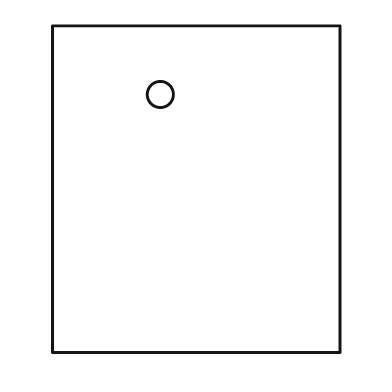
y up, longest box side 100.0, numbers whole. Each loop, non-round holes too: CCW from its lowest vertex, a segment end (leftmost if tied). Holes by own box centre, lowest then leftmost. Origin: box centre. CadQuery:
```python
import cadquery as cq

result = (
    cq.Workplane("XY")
    .moveTo(-44.0, -50.0)
    .lineTo(44.0, -50.0)
    .lineTo(44.0, 50.0)
    .lineTo(-44.0, 50.0)
    .close()
    .moveTo(-11.0, 29.0)
    .circle(4.0)
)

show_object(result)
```